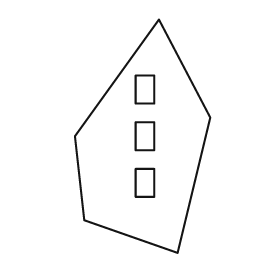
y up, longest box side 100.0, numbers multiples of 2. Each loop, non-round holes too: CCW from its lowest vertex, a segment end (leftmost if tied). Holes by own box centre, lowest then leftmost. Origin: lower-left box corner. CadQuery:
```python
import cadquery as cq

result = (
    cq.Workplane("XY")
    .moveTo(44.0, 0.0)
    .lineTo(58.0, 58.0)
    .lineTo(36.0, 100.0)
    .lineTo(0.0, 50.0)
    .lineTo(4.0, 14.0)
    .close()
    .moveTo(26.0, 24.0)
    .lineTo(34.0, 24.0)
    .lineTo(34.0, 36.0)
    .lineTo(26.0, 36.0)
    .close()
    .moveTo(26.0, 44.0)
    .lineTo(34.0, 44.0)
    .lineTo(34.0, 56.0)
    .lineTo(26.0, 56.0)
    .close()
    .moveTo(26.0, 64.0)
    .lineTo(34.0, 64.0)
    .lineTo(34.0, 76.0)
    .lineTo(26.0, 76.0)
    .close()
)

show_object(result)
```